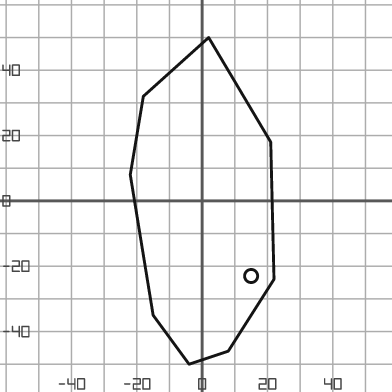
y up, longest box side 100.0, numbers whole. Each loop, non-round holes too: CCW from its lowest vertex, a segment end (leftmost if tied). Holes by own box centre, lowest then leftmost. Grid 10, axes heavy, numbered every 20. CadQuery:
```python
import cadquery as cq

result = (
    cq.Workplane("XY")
    .moveTo(-4.0, -50.0)
    .lineTo(8.0, -46.0)
    .lineTo(22.0, -24.0)
    .lineTo(21.0, 18.0)
    .lineTo(2.0, 50.0)
    .lineTo(-18.0, 32.0)
    .lineTo(-22.0, 8.0)
    .lineTo(-15.0, -35.0)
    .close()
    .moveTo(15.0, -23.0)
    .circle(2.0)
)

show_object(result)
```